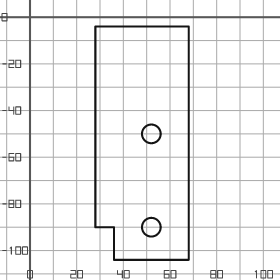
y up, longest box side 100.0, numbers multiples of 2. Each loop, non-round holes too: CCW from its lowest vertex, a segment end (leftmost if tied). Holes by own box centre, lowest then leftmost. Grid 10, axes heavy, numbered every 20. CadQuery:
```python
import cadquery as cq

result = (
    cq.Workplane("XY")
    .moveTo(36.0, -104.0)
    .lineTo(68.0, -104.0)
    .lineTo(68.0, -4.0)
    .lineTo(28.0, -4.0)
    .lineTo(28.0, -90.0)
    .lineTo(36.0, -90.0)
    .close()
    .moveTo(52.0, -90.0)
    .circle(4.0)
    .moveTo(52.0, -50.0)
    .circle(4.0)
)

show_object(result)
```